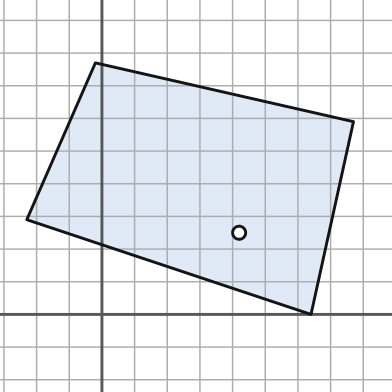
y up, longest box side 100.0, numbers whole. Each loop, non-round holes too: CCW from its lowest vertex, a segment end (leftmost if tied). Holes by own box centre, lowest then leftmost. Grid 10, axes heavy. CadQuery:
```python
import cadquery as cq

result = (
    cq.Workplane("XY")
    .moveTo(64.0, 0.0)
    .lineTo(77.0, 59.0)
    .lineTo(-2.0, 77.0)
    .lineTo(-23.0, 29.0)
    .close()
    .moveTo(42.0, 25.0)
    .circle(2.0)
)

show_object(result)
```